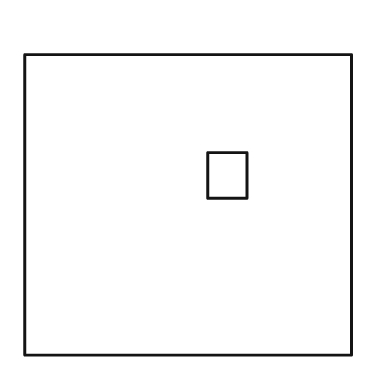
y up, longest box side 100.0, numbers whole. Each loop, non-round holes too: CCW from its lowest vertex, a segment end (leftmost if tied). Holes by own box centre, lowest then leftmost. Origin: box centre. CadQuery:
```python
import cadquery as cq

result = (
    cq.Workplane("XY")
    .moveTo(-50.0, -46.0)
    .lineTo(50.0, -46.0)
    .lineTo(50.0, 46.0)
    .lineTo(-50.0, 46.0)
    .close()
    .moveTo(6.0, 2.0)
    .lineTo(18.0, 2.0)
    .lineTo(18.0, 16.0)
    .lineTo(6.0, 16.0)
    .close()
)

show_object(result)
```